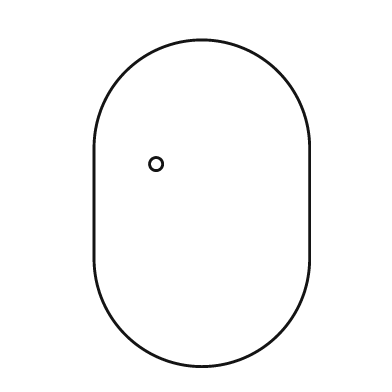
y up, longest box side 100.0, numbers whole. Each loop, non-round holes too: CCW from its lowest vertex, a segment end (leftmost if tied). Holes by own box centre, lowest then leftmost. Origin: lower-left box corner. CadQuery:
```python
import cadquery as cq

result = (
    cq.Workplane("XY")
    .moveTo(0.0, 33.0)
    .threePointArc((33.0, 0.0), (66.0, 33.0))
    .lineTo(66.0, 67.0)
    .threePointArc((33.0, 100.0), (0.0, 67.0))
    .close()
    .moveTo(19.0, 62.0)
    .circle(2.0)
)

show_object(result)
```